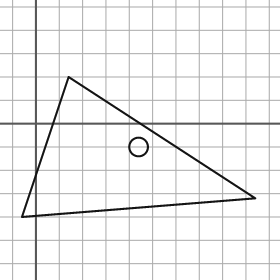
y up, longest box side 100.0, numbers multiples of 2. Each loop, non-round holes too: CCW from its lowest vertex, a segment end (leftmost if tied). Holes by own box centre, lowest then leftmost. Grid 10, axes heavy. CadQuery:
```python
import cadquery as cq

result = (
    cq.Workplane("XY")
    .moveTo(-6.0, -40.0)
    .lineTo(94.0, -32.0)
    .lineTo(14.0, 20.0)
    .close()
    .moveTo(44.0, -10.0)
    .circle(4.0)
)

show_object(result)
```